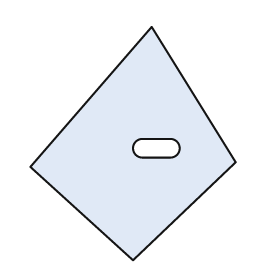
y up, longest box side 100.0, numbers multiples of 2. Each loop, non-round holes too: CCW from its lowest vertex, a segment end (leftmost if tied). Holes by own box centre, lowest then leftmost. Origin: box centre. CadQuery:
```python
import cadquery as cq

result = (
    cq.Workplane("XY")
    .moveTo(0.0, -50.0)
    .lineTo(44.0, -8.0)
    .lineTo(8.0, 50.0)
    .lineTo(-44.0, -10.0)
    .close()
    .moveTo(4.0, -6.0)
    .lineTo(16.0, -6.0)
    .threePointArc((20.0, -2.0), (16.0, 2.0))
    .lineTo(4.0, 2.0)
    .threePointArc((0.0, -2.0), (4.0, -6.0))
    .close()
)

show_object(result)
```